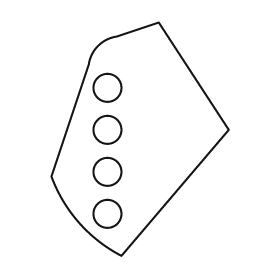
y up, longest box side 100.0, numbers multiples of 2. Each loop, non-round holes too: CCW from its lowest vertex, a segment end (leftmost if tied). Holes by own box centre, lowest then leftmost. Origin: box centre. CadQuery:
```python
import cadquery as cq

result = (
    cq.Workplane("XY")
    .moveTo(-8.0, -50.0)
    .lineTo(38.0, 4.0)
    .lineTo(8.0, 50.0)
    .lineTo(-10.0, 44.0)
    .threePointArc((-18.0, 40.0), (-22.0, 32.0))
    .lineTo(-38.0, -16.0)
    .threePointArc((-26.0, -36.0), (-8.0, -50.0))
    .close()
    .moveTo(-14.0, -32.0)
    .circle(6.0)
    .moveTo(-14.0, -14.0)
    .circle(6.0)
    .moveTo(-14.0, 4.0)
    .circle(6.0)
    .moveTo(-14.0, 22.0)
    .circle(6.0)
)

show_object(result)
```